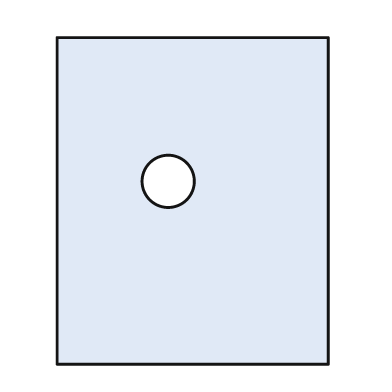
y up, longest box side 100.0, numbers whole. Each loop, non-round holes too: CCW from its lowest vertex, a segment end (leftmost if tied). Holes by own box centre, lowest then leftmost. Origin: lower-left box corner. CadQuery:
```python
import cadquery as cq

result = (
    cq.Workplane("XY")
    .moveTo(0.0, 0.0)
    .lineTo(83.0, 0.0)
    .lineTo(83.0, 100.0)
    .lineTo(0.0, 100.0)
    .close()
    .moveTo(34.0, 56.0)
    .circle(8.0)
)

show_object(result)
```